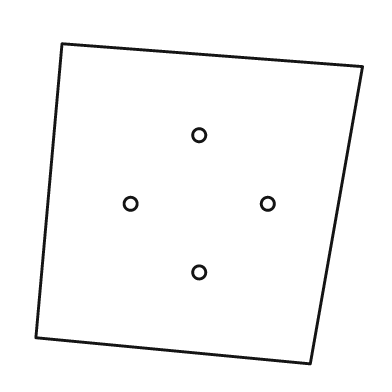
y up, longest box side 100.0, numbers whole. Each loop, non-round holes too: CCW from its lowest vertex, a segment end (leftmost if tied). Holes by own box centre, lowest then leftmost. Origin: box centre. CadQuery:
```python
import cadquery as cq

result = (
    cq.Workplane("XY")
    .moveTo(34.0, -49.0)
    .lineTo(50.0, 42.0)
    .lineTo(-42.0, 49.0)
    .lineTo(-50.0, -41.0)
    .close()
    .moveTo(0.0, -21.0)
    .circle(2.0)
    .moveTo(-21.0, 0.0)
    .circle(2.0)
    .moveTo(21.0, 0.0)
    .circle(2.0)
    .moveTo(0.0, 21.0)
    .circle(2.0)
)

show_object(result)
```